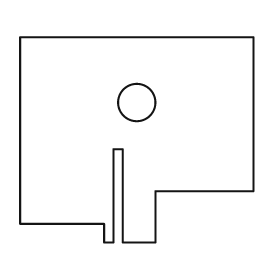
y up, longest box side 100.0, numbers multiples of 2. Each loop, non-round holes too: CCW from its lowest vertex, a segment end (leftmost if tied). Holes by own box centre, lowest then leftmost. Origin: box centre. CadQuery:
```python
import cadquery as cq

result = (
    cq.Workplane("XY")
    .moveTo(-14.0, -44.0)
    .lineTo(-10.0, -44.0)
    .lineTo(-10.0, -4.0)
    .lineTo(-6.0, -4.0)
    .lineTo(-6.0, -44.0)
    .lineTo(8.0, -44.0)
    .lineTo(8.0, -22.0)
    .lineTo(50.0, -22.0)
    .lineTo(50.0, 44.0)
    .lineTo(-50.0, 44.0)
    .lineTo(-50.0, -36.0)
    .lineTo(-14.0, -36.0)
    .close()
    .moveTo(0.0, 16.0)
    .circle(8.0)
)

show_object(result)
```